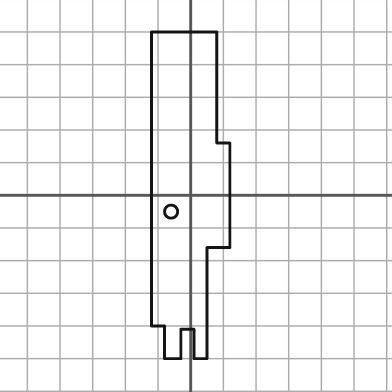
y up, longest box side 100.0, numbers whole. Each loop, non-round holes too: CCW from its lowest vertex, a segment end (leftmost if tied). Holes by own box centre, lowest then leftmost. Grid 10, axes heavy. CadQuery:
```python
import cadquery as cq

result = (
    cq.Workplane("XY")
    .moveTo(-8.0, -50.0)
    .lineTo(-3.0, -50.0)
    .lineTo(-3.0, -41.0)
    .lineTo(1.0, -41.0)
    .lineTo(1.0, -50.0)
    .lineTo(5.0, -50.0)
    .lineTo(5.0, -16.0)
    .lineTo(12.0, -16.0)
    .lineTo(12.0, 16.0)
    .lineTo(8.0, 16.0)
    .lineTo(8.0, 50.0)
    .lineTo(-12.0, 50.0)
    .lineTo(-12.0, -40.0)
    .lineTo(-8.0, -40.0)
    .close()
    .moveTo(-6.0, -5.0)
    .circle(2.0)
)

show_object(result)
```